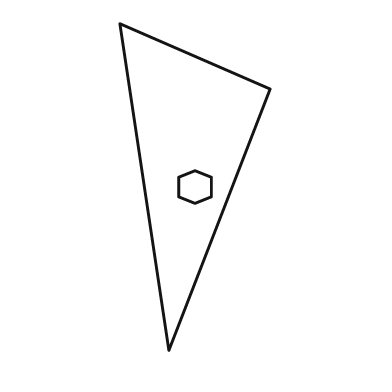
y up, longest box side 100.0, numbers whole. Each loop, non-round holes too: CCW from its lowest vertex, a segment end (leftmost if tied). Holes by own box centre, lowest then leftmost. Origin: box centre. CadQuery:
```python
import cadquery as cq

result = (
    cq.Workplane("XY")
    .moveTo(-8.0, -50.0)
    .lineTo(23.0, 30.0)
    .lineTo(-23.0, 50.0)
    .close()
    .moveTo(0.0, -5.0)
    .lineTo(5.0, -3.0)
    .lineTo(5.0, 3.0)
    .lineTo(0.0, 5.0)
    .lineTo(-5.0, 3.0)
    .lineTo(-5.0, -3.0)
    .close()
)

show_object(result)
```